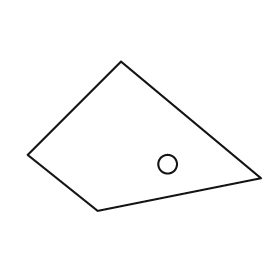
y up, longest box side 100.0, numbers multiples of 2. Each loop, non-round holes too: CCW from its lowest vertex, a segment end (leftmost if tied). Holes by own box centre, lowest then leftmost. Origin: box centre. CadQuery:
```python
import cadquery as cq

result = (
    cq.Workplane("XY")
    .moveTo(-20.0, -32.0)
    .lineTo(50.0, -18.0)
    .lineTo(-10.0, 32.0)
    .lineTo(-50.0, -8.0)
    .close()
    .moveTo(10.0, -12.0)
    .circle(4.0)
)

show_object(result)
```